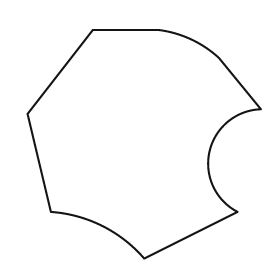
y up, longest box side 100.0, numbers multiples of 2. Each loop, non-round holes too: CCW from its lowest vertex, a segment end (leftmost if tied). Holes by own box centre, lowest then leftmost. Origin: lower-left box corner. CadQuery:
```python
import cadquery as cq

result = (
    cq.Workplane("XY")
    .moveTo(50.0, 0.0)
    .lineTo(90.0, 20.0)
    .threePointArc((78.0, 46.0), (100.0, 64.0))
    .lineTo(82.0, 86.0)
    .threePointArc((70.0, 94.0), (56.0, 98.0))
    .lineTo(28.0, 98.0)
    .lineTo(0.0, 62.0)
    .lineTo(10.0, 20.0)
    .threePointArc((32.0, 14.0), (50.0, 0.0))
    .close()
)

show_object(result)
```